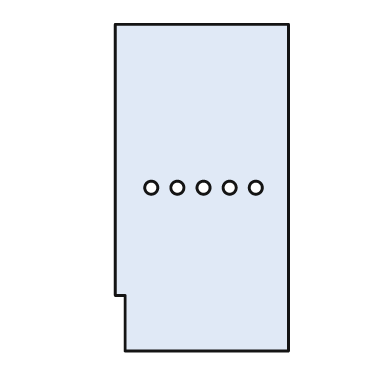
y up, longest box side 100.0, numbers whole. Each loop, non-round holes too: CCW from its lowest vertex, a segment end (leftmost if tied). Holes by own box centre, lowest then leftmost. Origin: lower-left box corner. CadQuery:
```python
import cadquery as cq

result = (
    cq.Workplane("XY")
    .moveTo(3.0, 0.0)
    .lineTo(53.0, 0.0)
    .lineTo(53.0, 100.0)
    .lineTo(0.0, 100.0)
    .lineTo(0.0, 17.0)
    .lineTo(3.0, 17.0)
    .close()
    .moveTo(11.0, 50.0)
    .circle(2.0)
    .moveTo(19.0, 50.0)
    .circle(2.0)
    .moveTo(27.0, 50.0)
    .circle(2.0)
    .moveTo(35.0, 50.0)
    .circle(2.0)
    .moveTo(43.0, 50.0)
    .circle(2.0)
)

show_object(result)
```